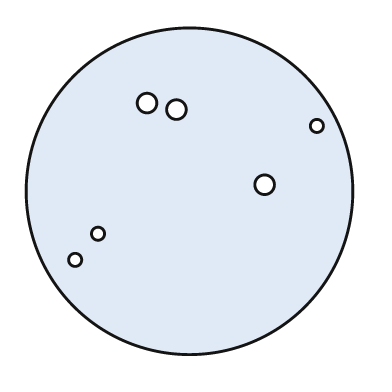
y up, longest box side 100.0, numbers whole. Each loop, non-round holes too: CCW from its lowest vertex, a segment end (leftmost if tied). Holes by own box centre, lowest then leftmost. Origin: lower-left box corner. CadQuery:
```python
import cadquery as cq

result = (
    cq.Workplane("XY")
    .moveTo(50.0, 50.0)
    .circle(50.0)
    .moveTo(15.0, 29.0)
    .circle(2.0)
    .moveTo(22.0, 37.0)
    .circle(2.0)
    .moveTo(73.0, 52.0)
    .circle(3.0)
    .moveTo(89.0, 70.0)
    .circle(2.0)
    .moveTo(46.0, 75.0)
    .circle(3.0)
    .moveTo(37.0, 77.0)
    .circle(3.0)
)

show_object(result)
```